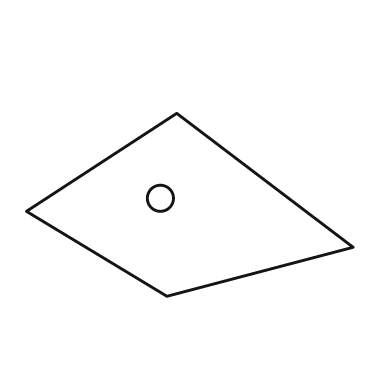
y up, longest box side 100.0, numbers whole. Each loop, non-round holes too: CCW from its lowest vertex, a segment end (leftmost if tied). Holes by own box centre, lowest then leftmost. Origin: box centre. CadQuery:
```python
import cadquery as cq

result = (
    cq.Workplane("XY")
    .moveTo(-7.0, -28.0)
    .lineTo(50.0, -13.0)
    .lineTo(-4.0, 28.0)
    .lineTo(-50.0, -2.0)
    .close()
    .moveTo(-9.0, 2.0)
    .circle(4.0)
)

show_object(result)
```